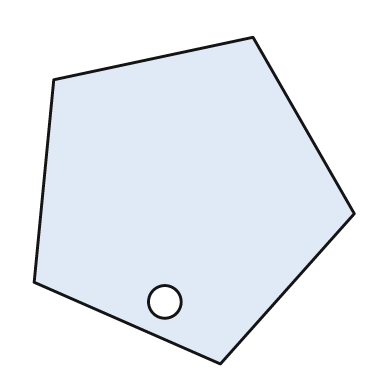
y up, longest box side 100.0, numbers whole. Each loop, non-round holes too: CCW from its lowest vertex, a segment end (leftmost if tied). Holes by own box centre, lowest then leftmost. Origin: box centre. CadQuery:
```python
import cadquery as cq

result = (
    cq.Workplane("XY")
    .moveTo(8.0, -50.0)
    .lineTo(49.0, -4.0)
    .lineTo(18.0, 50.0)
    .lineTo(-43.0, 37.0)
    .lineTo(-49.0, -25.0)
    .close()
    .moveTo(-9.0, -31.0)
    .circle(5.0)
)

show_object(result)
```